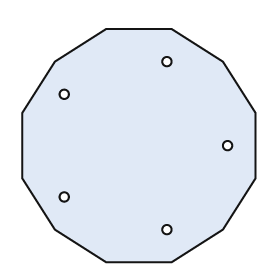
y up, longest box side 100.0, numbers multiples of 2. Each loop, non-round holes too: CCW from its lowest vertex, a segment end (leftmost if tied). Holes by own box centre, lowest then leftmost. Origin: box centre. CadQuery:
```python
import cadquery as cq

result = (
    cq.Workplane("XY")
    .moveTo(-14.0, -50.0)
    .lineTo(14.0, -50.0)
    .lineTo(36.0, -36.0)
    .lineTo(50.0, -14.0)
    .lineTo(50.0, 14.0)
    .lineTo(36.0, 36.0)
    .lineTo(14.0, 50.0)
    .lineTo(-14.0, 50.0)
    .lineTo(-36.0, 36.0)
    .lineTo(-50.0, 14.0)
    .lineTo(-50.0, -14.0)
    .lineTo(-36.0, -36.0)
    .close()
    .moveTo(12.0, -36.0)
    .circle(2.0)
    .moveTo(-32.0, -22.0)
    .circle(2.0)
    .moveTo(38.0, 0.0)
    .circle(2.0)
    .moveTo(-32.0, 22.0)
    .circle(2.0)
    .moveTo(12.0, 36.0)
    .circle(2.0)
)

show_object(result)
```